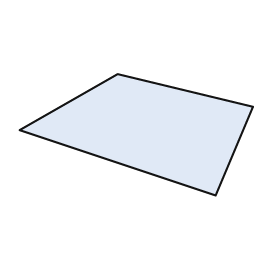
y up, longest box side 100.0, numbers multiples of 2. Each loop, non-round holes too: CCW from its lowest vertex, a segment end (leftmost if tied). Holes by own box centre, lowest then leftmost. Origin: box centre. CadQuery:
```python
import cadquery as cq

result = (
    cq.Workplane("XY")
    .moveTo(34.0, -26.0)
    .lineTo(50.0, 12.0)
    .lineTo(-8.0, 26.0)
    .lineTo(-50.0, 2.0)
    .close()
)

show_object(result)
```